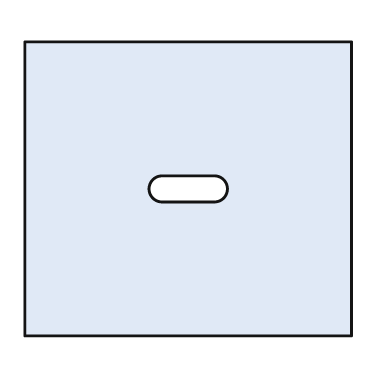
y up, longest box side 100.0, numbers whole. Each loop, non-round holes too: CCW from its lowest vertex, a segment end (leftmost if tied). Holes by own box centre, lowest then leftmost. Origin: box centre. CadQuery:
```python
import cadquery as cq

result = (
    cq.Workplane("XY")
    .moveTo(-50.0, -45.0)
    .lineTo(50.0, -45.0)
    .lineTo(50.0, 45.0)
    .lineTo(-50.0, 45.0)
    .close()
    .moveTo(-8.0, -4.0)
    .lineTo(8.0, -4.0)
    .threePointArc((12.0, 0.0), (8.0, 4.0))
    .lineTo(-8.0, 4.0)
    .threePointArc((-12.0, 0.0), (-8.0, -4.0))
    .close()
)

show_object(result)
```